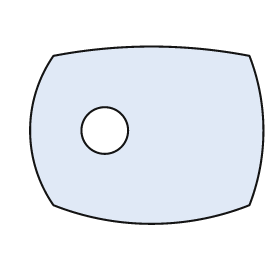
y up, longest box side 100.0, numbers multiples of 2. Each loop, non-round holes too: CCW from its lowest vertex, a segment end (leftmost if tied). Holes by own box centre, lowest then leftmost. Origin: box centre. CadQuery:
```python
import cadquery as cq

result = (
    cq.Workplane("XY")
    .moveTo(-40.0, -30.0)
    .threePointArc((2.0, -38.0), (44.0, -30.0))
    .threePointArc((50.0, 2.0), (44.0, 34.0))
    .threePointArc((2.0, 38.0), (-40.0, 34.0))
    .threePointArc((-50.0, 2.0), (-40.0, -30.0))
    .close()
    .moveTo(-18.0, 2.0)
    .circle(10.0)
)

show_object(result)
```